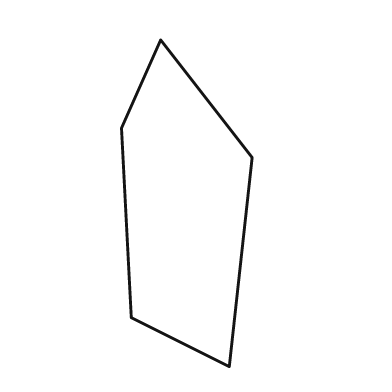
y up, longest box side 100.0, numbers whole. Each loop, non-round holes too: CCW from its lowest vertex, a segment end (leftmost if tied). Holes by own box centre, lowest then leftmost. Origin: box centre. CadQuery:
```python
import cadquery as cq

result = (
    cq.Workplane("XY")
    .moveTo(13.0, -50.0)
    .lineTo(20.0, 14.0)
    .lineTo(-8.0, 50.0)
    .lineTo(-20.0, 23.0)
    .lineTo(-17.0, -35.0)
    .close()
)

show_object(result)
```